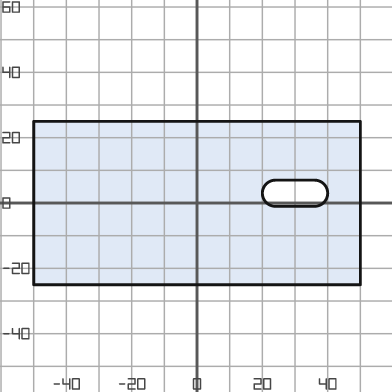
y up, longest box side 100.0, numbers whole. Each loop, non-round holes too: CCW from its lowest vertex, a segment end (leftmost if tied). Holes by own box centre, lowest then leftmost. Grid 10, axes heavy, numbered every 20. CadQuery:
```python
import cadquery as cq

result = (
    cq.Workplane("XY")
    .moveTo(-50.0, -25.0)
    .lineTo(50.0, -25.0)
    .lineTo(50.0, 25.0)
    .lineTo(-50.0, 25.0)
    .close()
    .moveTo(24.0, -1.0)
    .lineTo(36.0, -1.0)
    .threePointArc((40.0, 3.0), (36.0, 7.0))
    .lineTo(24.0, 7.0)
    .threePointArc((20.0, 3.0), (24.0, -1.0))
    .close()
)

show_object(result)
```